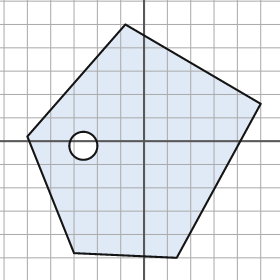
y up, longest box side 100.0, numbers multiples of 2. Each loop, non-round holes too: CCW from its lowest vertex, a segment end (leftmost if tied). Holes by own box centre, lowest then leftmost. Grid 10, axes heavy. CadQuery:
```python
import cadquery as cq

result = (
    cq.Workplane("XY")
    .moveTo(14.0, -50.0)
    .lineTo(50.0, 16.0)
    .lineTo(-8.0, 50.0)
    .lineTo(-50.0, 2.0)
    .lineTo(-30.0, -48.0)
    .close()
    .moveTo(-26.0, -2.0)
    .circle(6.0)
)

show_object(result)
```